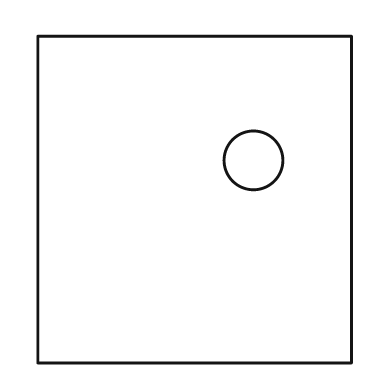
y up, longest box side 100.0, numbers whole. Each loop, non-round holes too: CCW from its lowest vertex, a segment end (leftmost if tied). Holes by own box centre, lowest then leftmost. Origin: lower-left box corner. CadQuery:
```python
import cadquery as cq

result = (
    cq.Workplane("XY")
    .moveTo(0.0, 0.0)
    .lineTo(96.0, 0.0)
    .lineTo(96.0, 100.0)
    .lineTo(0.0, 100.0)
    .close()
    .moveTo(66.0, 62.0)
    .circle(9.0)
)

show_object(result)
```